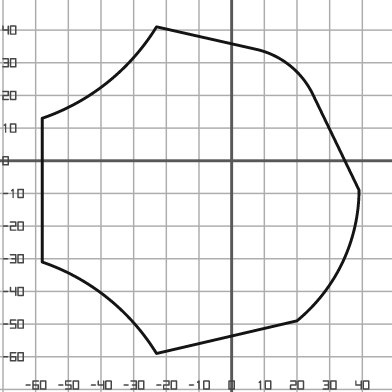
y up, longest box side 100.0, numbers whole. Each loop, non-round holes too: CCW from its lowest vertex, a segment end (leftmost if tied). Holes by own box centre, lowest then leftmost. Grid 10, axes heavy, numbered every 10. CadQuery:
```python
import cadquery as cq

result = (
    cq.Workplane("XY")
    .moveTo(-23.0, -59.0)
    .lineTo(20.0, -49.0)
    .threePointArc((34.0, -31.0), (39.0, -9.0))
    .lineTo(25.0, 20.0)
    .threePointArc((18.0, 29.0), (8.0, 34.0))
    .lineTo(-23.0, 41.0)
    .threePointArc((-38.0, 24.0), (-58.0, 13.0))
    .lineTo(-58.0, -31.0)
    .threePointArc((-38.0, -42.0), (-23.0, -59.0))
    .close()
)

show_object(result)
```